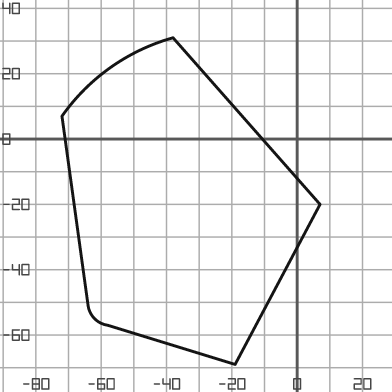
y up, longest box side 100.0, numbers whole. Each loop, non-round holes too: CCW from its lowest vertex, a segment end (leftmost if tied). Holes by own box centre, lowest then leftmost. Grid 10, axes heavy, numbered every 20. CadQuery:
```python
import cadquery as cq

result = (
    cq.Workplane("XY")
    .moveTo(-19.0, -69.0)
    .lineTo(7.0, -20.0)
    .lineTo(-38.0, 31.0)
    .threePointArc((-57.0, 22.0), (-72.0, 7.0))
    .lineTo(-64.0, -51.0)
    .threePointArc((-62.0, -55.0), (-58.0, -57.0))
    .close()
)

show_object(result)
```